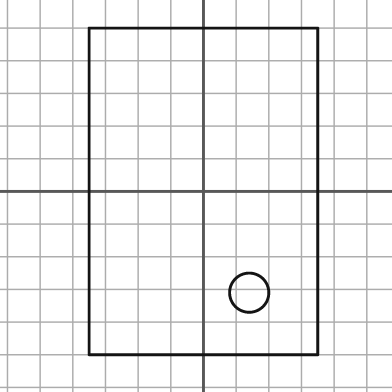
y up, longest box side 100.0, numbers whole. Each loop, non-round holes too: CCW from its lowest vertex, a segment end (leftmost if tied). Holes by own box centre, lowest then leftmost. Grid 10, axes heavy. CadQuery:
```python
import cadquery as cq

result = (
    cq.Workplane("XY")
    .moveTo(-35.0, -50.0)
    .lineTo(35.0, -50.0)
    .lineTo(35.0, 50.0)
    .lineTo(-35.0, 50.0)
    .close()
    .moveTo(14.0, -31.0)
    .circle(6.0)
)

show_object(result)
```